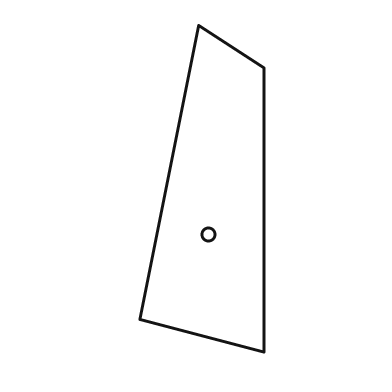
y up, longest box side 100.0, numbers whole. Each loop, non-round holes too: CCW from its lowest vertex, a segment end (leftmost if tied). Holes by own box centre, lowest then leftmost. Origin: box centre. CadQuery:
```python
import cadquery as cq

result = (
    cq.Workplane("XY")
    .moveTo(19.0, -50.0)
    .lineTo(19.0, 37.0)
    .lineTo(-1.0, 50.0)
    .lineTo(-19.0, -40.0)
    .close()
    .moveTo(2.0, -14.0)
    .circle(2.0)
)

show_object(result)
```